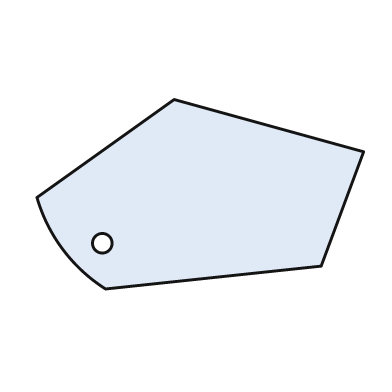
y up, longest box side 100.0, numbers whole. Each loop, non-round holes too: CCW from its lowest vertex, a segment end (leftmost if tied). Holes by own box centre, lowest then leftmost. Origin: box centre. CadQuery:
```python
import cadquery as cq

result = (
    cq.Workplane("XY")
    .moveTo(-29.0, -29.0)
    .lineTo(37.0, -22.0)
    .lineTo(50.0, 13.0)
    .lineTo(-8.0, 29.0)
    .lineTo(-50.0, -1.0)
    .threePointArc((-42.0, -17.0), (-29.0, -29.0))
    .close()
    .moveTo(-30.0, -15.0)
    .circle(3.0)
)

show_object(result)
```